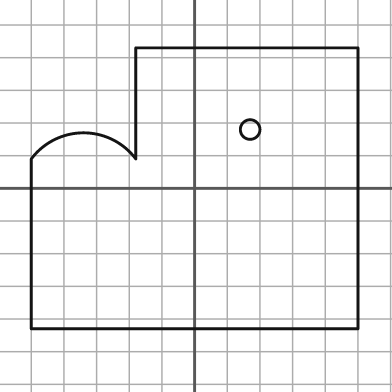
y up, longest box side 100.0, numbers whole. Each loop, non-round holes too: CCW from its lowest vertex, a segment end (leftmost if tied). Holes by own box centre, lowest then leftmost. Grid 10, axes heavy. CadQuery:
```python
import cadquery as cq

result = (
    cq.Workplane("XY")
    .moveTo(-50.0, -43.0)
    .lineTo(50.0, -43.0)
    .lineTo(50.0, 43.0)
    .lineTo(-18.0, 43.0)
    .lineTo(-18.0, 9.0)
    .threePointArc((-34.0, 17.0), (-50.0, 9.0))
    .close()
    .moveTo(17.0, 18.0)
    .circle(3.0)
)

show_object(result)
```